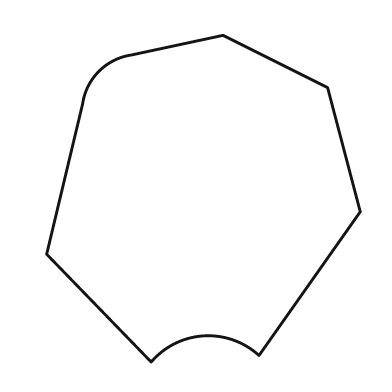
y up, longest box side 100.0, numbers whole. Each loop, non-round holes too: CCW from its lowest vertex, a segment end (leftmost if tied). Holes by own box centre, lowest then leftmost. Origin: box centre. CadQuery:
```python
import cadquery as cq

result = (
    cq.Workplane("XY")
    .moveTo(-16.0, -50.0)
    .threePointArc((0.0, -42.0), (17.0, -48.0))
    .lineTo(48.0, -4.0)
    .lineTo(38.0, 34.0)
    .lineTo(6.0, 50.0)
    .lineTo(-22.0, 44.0)
    .threePointArc((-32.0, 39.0), (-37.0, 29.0))
    .lineTo(-48.0, -17.0)
    .close()
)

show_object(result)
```